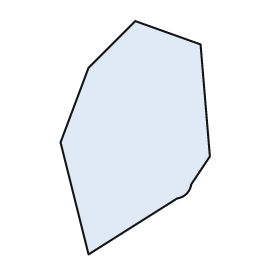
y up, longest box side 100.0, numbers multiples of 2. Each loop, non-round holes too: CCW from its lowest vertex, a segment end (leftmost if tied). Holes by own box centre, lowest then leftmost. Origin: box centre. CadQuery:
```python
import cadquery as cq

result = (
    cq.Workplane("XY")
    .moveTo(-20.0, -50.0)
    .lineTo(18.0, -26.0)
    .threePointArc((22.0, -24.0), (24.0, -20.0))
    .lineTo(32.0, -8.0)
    .lineTo(28.0, 40.0)
    .lineTo(0.0, 50.0)
    .lineTo(-20.0, 30.0)
    .lineTo(-32.0, -2.0)
    .close()
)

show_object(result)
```